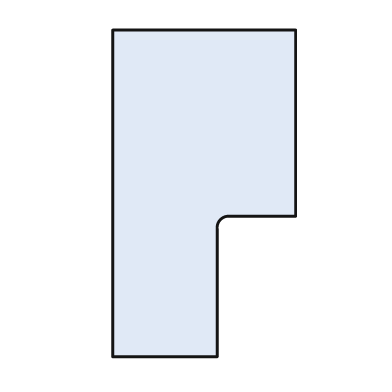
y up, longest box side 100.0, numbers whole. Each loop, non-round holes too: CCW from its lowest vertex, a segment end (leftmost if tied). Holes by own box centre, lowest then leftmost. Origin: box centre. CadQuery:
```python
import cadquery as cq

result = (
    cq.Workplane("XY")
    .moveTo(-28.0, -50.0)
    .lineTo(4.0, -50.0)
    .lineTo(4.0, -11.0)
    .threePointArc((5.0, -8.0), (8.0, -7.0))
    .lineTo(28.0, -7.0)
    .lineTo(28.0, 50.0)
    .lineTo(-28.0, 50.0)
    .close()
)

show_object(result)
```